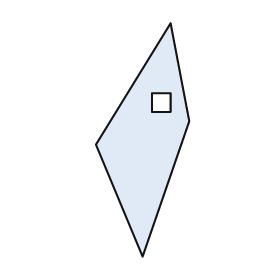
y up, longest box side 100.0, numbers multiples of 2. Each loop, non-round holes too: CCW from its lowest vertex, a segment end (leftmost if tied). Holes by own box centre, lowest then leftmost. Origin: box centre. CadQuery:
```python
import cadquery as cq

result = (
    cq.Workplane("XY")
    .moveTo(0.0, -50.0)
    .lineTo(20.0, 8.0)
    .lineTo(12.0, 50.0)
    .lineTo(-20.0, -2.0)
    .close()
    .moveTo(4.0, 12.0)
    .lineTo(12.0, 12.0)
    .lineTo(12.0, 20.0)
    .lineTo(4.0, 20.0)
    .close()
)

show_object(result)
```